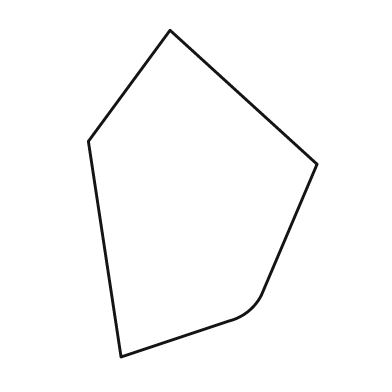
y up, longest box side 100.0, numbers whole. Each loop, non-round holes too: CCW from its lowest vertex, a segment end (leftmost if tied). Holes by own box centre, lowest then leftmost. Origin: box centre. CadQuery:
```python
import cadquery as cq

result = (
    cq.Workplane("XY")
    .moveTo(-25.0, -50.0)
    .lineTo(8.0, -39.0)
    .threePointArc((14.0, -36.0), (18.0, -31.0))
    .lineTo(35.0, 9.0)
    .lineTo(-10.0, 50.0)
    .lineTo(-35.0, 16.0)
    .close()
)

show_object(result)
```